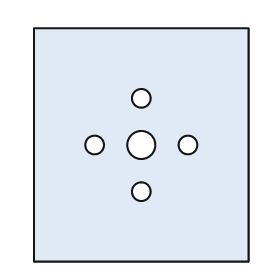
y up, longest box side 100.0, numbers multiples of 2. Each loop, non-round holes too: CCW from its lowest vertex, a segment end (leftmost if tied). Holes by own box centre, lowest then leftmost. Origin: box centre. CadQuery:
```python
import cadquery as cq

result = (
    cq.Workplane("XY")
    .moveTo(-46.0, -50.0)
    .lineTo(46.0, -50.0)
    .lineTo(46.0, 50.0)
    .lineTo(-46.0, 50.0)
    .close()
    .moveTo(0.0, -20.0)
    .circle(4.0)
    .moveTo(-20.0, 0.0)
    .circle(4.0)
    .moveTo(0.0, 0.0)
    .circle(6.0)
    .moveTo(20.0, 0.0)
    .circle(4.0)
    .moveTo(0.0, 20.0)
    .circle(4.0)
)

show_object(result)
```